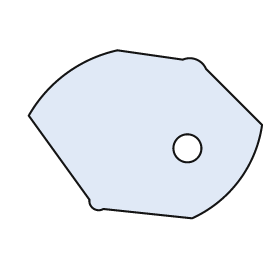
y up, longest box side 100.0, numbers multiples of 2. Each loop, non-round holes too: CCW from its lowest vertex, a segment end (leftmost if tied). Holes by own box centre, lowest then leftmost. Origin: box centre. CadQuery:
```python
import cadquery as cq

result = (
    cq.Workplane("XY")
    .moveTo(20.0, -36.0)
    .threePointArc((40.0, -20.0), (50.0, 4.0))
    .lineTo(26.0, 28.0)
    .threePointArc((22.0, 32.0), (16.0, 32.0))
    .lineTo(-12.0, 36.0)
    .threePointArc((-34.0, 26.0), (-50.0, 8.0))
    .lineTo(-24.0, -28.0)
    .threePointArc((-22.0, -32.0), (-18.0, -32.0))
    .close()
    .moveTo(18.0, -6.0)
    .circle(6.0)
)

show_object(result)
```